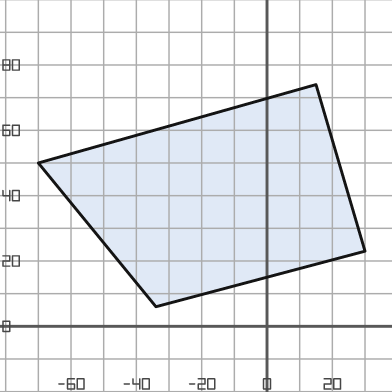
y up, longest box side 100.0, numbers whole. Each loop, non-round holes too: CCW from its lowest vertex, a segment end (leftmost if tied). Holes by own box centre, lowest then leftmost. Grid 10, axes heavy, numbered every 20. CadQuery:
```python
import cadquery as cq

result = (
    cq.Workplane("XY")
    .moveTo(-34.0, 6.0)
    .lineTo(30.0, 23.0)
    .lineTo(15.0, 74.0)
    .lineTo(-70.0, 50.0)
    .close()
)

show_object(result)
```